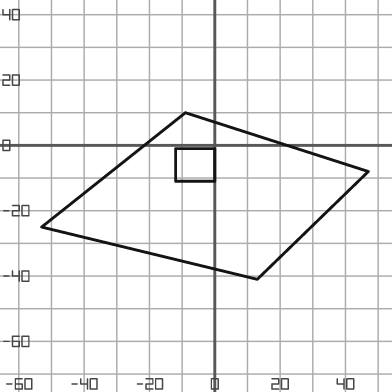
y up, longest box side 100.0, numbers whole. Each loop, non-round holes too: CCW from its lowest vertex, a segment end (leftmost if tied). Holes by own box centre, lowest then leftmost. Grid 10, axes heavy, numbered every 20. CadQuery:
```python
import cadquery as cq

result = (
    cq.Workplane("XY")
    .moveTo(13.0, -41.0)
    .lineTo(47.0, -8.0)
    .lineTo(-9.0, 10.0)
    .lineTo(-53.0, -25.0)
    .close()
    .moveTo(-12.0, -11.0)
    .lineTo(0.0, -11.0)
    .lineTo(0.0, -1.0)
    .lineTo(-12.0, -1.0)
    .close()
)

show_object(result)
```